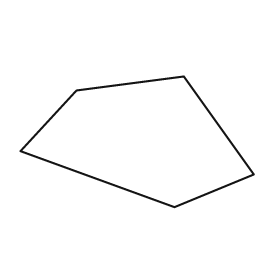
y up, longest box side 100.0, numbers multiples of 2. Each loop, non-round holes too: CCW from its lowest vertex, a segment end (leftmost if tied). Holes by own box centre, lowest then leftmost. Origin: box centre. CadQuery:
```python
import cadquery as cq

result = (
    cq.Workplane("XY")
    .moveTo(16.0, -28.0)
    .lineTo(50.0, -14.0)
    .lineTo(20.0, 28.0)
    .lineTo(-26.0, 22.0)
    .lineTo(-50.0, -4.0)
    .close()
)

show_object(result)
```